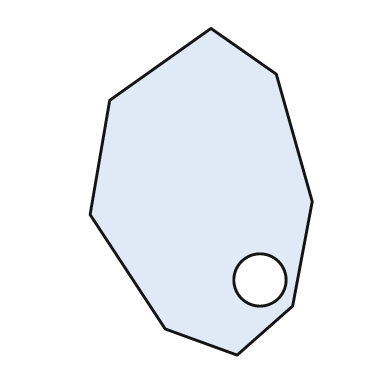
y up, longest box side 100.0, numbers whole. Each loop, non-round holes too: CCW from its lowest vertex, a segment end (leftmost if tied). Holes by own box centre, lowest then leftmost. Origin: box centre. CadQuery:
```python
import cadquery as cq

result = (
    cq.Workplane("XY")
    .moveTo(11.0, -50.0)
    .lineTo(28.0, -35.0)
    .lineTo(34.0, -3.0)
    .lineTo(23.0, 36.0)
    .lineTo(3.0, 50.0)
    .lineTo(-28.0, 28.0)
    .lineTo(-34.0, -7.0)
    .lineTo(-11.0, -42.0)
    .close()
    .moveTo(18.0, -27.0)
    .circle(8.0)
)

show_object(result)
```